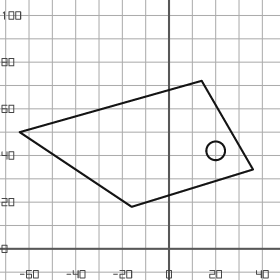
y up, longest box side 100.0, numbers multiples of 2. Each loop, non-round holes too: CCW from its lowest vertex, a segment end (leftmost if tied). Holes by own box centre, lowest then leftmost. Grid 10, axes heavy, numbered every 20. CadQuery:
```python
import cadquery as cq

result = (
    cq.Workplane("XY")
    .moveTo(-16.0, 18.0)
    .lineTo(36.0, 34.0)
    .lineTo(14.0, 72.0)
    .lineTo(-64.0, 50.0)
    .close()
    .moveTo(20.0, 42.0)
    .circle(4.0)
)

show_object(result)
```